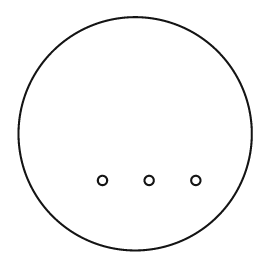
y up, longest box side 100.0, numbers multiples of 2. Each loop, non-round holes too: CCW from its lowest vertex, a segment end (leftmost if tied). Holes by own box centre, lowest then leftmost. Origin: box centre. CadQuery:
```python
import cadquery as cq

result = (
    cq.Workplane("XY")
    .moveTo(0.0, 0.0)
    .circle(50.0)
    .moveTo(-14.0, -20.0)
    .circle(2.0)
    .moveTo(6.0, -20.0)
    .circle(2.0)
    .moveTo(26.0, -20.0)
    .circle(2.0)
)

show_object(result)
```